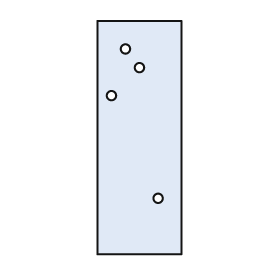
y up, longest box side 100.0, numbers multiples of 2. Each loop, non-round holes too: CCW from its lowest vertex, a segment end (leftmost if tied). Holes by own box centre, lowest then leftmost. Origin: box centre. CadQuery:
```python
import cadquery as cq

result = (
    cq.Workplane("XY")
    .moveTo(-18.0, -50.0)
    .lineTo(18.0, -50.0)
    .lineTo(18.0, 50.0)
    .lineTo(-18.0, 50.0)
    .close()
    .moveTo(8.0, -26.0)
    .circle(2.0)
    .moveTo(-12.0, 18.0)
    .circle(2.0)
    .moveTo(0.0, 30.0)
    .circle(2.0)
    .moveTo(-6.0, 38.0)
    .circle(2.0)
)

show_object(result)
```